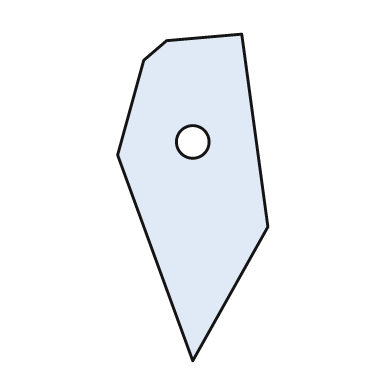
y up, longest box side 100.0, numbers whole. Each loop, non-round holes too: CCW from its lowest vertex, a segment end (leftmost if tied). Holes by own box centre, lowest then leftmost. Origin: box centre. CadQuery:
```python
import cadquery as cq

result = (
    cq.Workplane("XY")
    .moveTo(0.0, -50.0)
    .lineTo(23.0, -9.0)
    .lineTo(15.0, 50.0)
    .lineTo(-8.0, 48.0)
    .lineTo(-15.0, 42.0)
    .lineTo(-23.0, 13.0)
    .close()
    .moveTo(0.0, 17.0)
    .circle(5.0)
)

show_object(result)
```